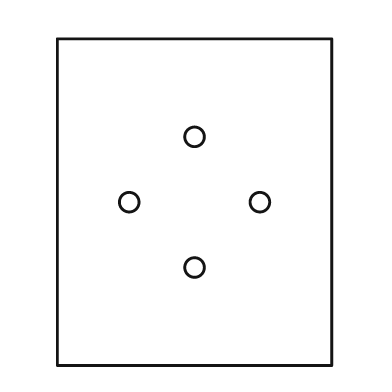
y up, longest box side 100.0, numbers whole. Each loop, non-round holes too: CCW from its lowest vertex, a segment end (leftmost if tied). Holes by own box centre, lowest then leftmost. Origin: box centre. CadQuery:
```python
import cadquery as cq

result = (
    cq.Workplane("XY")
    .moveTo(-42.0, -50.0)
    .lineTo(42.0, -50.0)
    .lineTo(42.0, 50.0)
    .lineTo(-42.0, 50.0)
    .close()
    .moveTo(0.0, -20.0)
    .circle(3.0)
    .moveTo(-20.0, 0.0)
    .circle(3.0)
    .moveTo(20.0, 0.0)
    .circle(3.0)
    .moveTo(0.0, 20.0)
    .circle(3.0)
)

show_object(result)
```